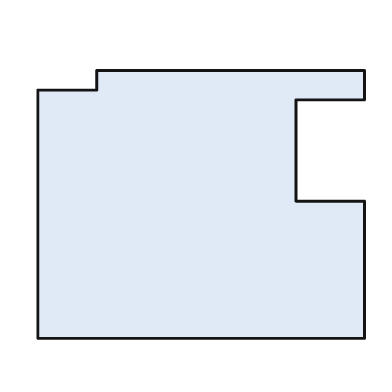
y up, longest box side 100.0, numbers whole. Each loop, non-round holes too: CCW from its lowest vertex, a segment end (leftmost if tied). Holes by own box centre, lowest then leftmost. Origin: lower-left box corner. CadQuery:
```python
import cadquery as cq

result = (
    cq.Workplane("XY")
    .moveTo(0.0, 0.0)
    .lineTo(100.0, 0.0)
    .lineTo(100.0, 42.0)
    .lineTo(79.0, 42.0)
    .lineTo(79.0, 73.0)
    .lineTo(100.0, 73.0)
    .lineTo(100.0, 82.0)
    .lineTo(18.0, 82.0)
    .lineTo(18.0, 76.0)
    .lineTo(0.0, 76.0)
    .close()
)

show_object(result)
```